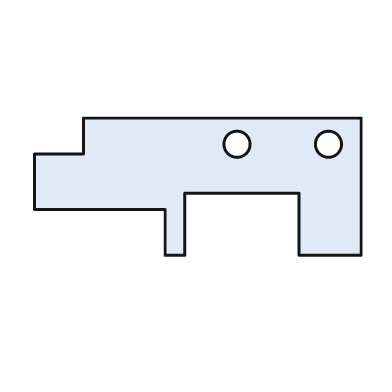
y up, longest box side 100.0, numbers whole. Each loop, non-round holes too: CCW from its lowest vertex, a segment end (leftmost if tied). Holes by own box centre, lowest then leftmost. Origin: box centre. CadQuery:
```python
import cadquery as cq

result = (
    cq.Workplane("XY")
    .moveTo(-10.0, -21.0)
    .lineTo(-4.0, -21.0)
    .lineTo(-4.0, -2.0)
    .lineTo(31.0, -2.0)
    .lineTo(31.0, -21.0)
    .lineTo(50.0, -21.0)
    .lineTo(50.0, 21.0)
    .lineTo(-35.0, 21.0)
    .lineTo(-35.0, 10.0)
    .lineTo(-50.0, 10.0)
    .lineTo(-50.0, -7.0)
    .lineTo(-10.0, -7.0)
    .close()
    .moveTo(12.0, 13.0)
    .circle(4.0)
    .moveTo(40.0, 13.0)
    .circle(4.0)
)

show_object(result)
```